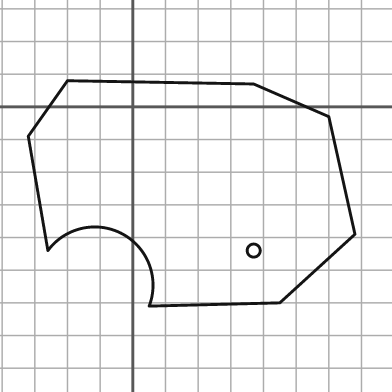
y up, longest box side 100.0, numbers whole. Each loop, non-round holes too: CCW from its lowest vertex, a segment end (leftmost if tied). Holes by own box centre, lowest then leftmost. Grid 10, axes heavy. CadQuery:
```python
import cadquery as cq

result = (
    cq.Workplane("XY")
    .moveTo(5.0, -61.0)
    .lineTo(45.0, -60.0)
    .lineTo(68.0, -39.0)
    .lineTo(60.0, -3.0)
    .lineTo(37.0, 7.0)
    .lineTo(-20.0, 8.0)
    .lineTo(-32.0, -9.0)
    .lineTo(-26.0, -44.0)
    .threePointArc((-3.0, -39.0), (5.0, -61.0))
    .close()
    .moveTo(37.0, -44.0)
    .circle(2.0)
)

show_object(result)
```